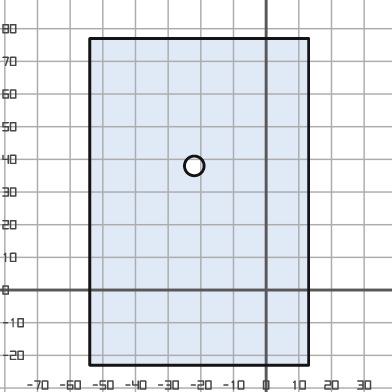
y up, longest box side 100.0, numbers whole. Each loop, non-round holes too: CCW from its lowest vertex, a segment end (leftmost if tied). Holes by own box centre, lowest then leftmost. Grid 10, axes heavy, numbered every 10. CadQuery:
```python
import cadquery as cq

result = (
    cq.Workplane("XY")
    .moveTo(-54.0, -23.0)
    .lineTo(13.0, -23.0)
    .lineTo(13.0, 77.0)
    .lineTo(-54.0, 77.0)
    .close()
    .moveTo(-22.0, 38.0)
    .circle(3.0)
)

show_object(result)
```